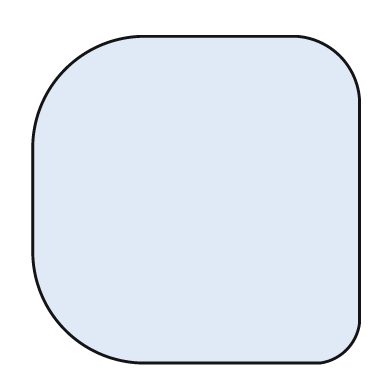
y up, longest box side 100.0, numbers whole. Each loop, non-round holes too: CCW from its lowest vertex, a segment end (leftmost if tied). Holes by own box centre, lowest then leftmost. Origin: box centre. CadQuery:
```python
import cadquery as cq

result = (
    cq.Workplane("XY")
    .moveTo(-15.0, -50.0)
    .lineTo(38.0, -50.0)
    .threePointArc((46.0, -46.0), (50.0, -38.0))
    .lineTo(50.0, 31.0)
    .threePointArc((44.0, 44.0), (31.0, 50.0))
    .lineTo(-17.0, 50.0)
    .threePointArc((-40.0, 40.0), (-50.0, 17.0))
    .lineTo(-50.0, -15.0)
    .threePointArc((-40.0, -40.0), (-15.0, -50.0))
    .close()
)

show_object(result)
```